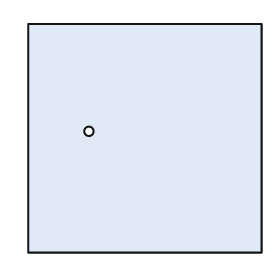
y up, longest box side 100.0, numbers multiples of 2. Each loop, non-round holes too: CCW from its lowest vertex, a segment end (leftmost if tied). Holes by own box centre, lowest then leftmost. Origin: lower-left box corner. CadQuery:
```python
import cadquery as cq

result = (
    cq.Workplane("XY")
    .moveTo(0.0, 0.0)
    .lineTo(100.0, 0.0)
    .lineTo(100.0, 98.0)
    .lineTo(0.0, 98.0)
    .close()
    .moveTo(26.0, 52.0)
    .circle(2.0)
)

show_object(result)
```